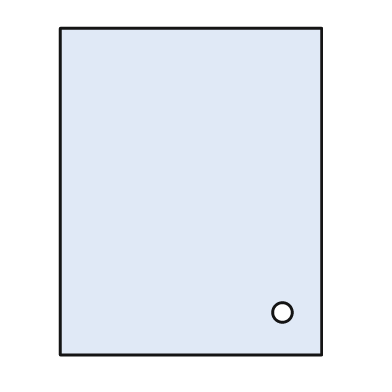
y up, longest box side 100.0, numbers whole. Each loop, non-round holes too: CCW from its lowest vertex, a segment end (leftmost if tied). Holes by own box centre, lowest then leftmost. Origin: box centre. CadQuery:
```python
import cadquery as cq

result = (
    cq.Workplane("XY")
    .moveTo(-40.0, -50.0)
    .lineTo(40.0, -50.0)
    .lineTo(40.0, 50.0)
    .lineTo(-40.0, 50.0)
    .close()
    .moveTo(28.0, -37.0)
    .circle(3.0)
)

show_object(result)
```